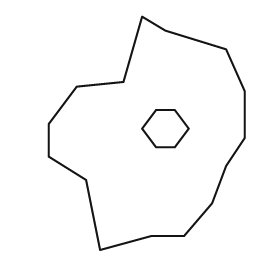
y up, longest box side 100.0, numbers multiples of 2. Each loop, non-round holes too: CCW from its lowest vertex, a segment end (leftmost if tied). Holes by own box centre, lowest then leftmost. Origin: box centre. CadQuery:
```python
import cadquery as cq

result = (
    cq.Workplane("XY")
    .moveTo(-20.0, -50.0)
    .lineTo(2.0, -44.0)
    .lineTo(16.0, -44.0)
    .lineTo(28.0, -30.0)
    .lineTo(34.0, -14.0)
    .lineTo(42.0, -2.0)
    .lineTo(42.0, 18.0)
    .lineTo(34.0, 36.0)
    .lineTo(8.0, 44.0)
    .lineTo(-2.0, 50.0)
    .lineTo(-10.0, 22.0)
    .lineTo(-30.0, 20.0)
    .lineTo(-42.0, 4.0)
    .lineTo(-42.0, -10.0)
    .lineTo(-26.0, -20.0)
    .close()
    .moveTo(4.0, -6.0)
    .lineTo(12.0, -6.0)
    .lineTo(18.0, 2.0)
    .lineTo(12.0, 10.0)
    .lineTo(4.0, 10.0)
    .lineTo(-2.0, 2.0)
    .close()
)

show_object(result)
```